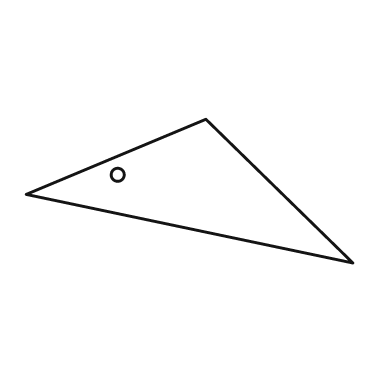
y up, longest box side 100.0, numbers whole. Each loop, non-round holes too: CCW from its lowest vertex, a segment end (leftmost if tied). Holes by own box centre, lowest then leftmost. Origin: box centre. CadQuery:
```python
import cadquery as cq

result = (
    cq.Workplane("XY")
    .moveTo(50.0, -22.0)
    .lineTo(5.0, 22.0)
    .lineTo(-50.0, -1.0)
    .close()
    .moveTo(-22.0, 5.0)
    .circle(2.0)
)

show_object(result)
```